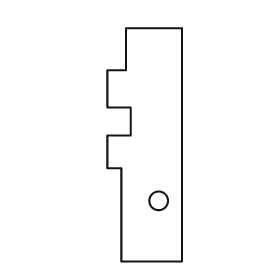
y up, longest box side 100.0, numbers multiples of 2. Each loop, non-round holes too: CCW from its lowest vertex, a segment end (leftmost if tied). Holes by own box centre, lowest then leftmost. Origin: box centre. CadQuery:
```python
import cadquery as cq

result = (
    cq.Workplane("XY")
    .moveTo(-10.0, -50.0)
    .lineTo(16.0, -50.0)
    .lineTo(16.0, 50.0)
    .lineTo(-8.0, 50.0)
    .lineTo(-8.0, 32.0)
    .lineTo(-16.0, 32.0)
    .lineTo(-16.0, 16.0)
    .lineTo(-6.0, 16.0)
    .lineTo(-6.0, 4.0)
    .lineTo(-16.0, 4.0)
    .lineTo(-16.0, -10.0)
    .lineTo(-10.0, -10.0)
    .close()
    .moveTo(6.0, -24.0)
    .circle(4.0)
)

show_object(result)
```